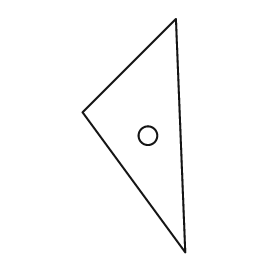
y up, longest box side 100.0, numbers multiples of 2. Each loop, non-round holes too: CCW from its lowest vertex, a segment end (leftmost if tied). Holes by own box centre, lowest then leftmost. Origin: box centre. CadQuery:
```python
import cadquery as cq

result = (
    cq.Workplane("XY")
    .moveTo(22.0, -50.0)
    .lineTo(18.0, 50.0)
    .lineTo(-22.0, 10.0)
    .close()
    .moveTo(6.0, 0.0)
    .circle(4.0)
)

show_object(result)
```